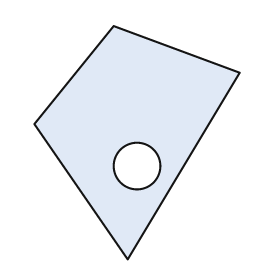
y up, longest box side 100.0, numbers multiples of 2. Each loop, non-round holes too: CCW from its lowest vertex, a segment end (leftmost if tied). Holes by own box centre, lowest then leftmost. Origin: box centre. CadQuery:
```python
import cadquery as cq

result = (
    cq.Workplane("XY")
    .moveTo(-4.0, -50.0)
    .lineTo(44.0, 30.0)
    .lineTo(-10.0, 50.0)
    .lineTo(-44.0, 8.0)
    .close()
    .moveTo(0.0, -10.0)
    .circle(10.0)
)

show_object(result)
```